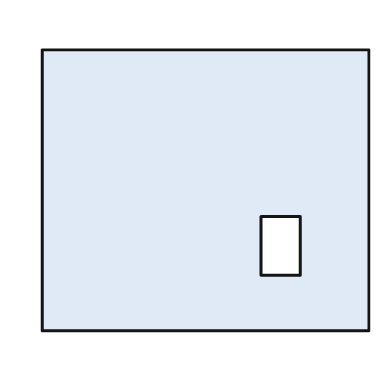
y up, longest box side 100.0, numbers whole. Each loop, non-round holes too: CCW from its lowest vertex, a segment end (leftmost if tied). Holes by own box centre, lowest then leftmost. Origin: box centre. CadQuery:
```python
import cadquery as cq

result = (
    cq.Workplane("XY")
    .moveTo(-50.0, -43.0)
    .lineTo(50.0, -43.0)
    .lineTo(50.0, 43.0)
    .lineTo(-50.0, 43.0)
    .close()
    .moveTo(17.0, -26.0)
    .lineTo(29.0, -26.0)
    .lineTo(29.0, -8.0)
    .lineTo(17.0, -8.0)
    .close()
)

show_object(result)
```